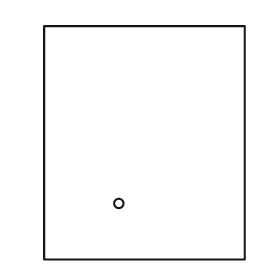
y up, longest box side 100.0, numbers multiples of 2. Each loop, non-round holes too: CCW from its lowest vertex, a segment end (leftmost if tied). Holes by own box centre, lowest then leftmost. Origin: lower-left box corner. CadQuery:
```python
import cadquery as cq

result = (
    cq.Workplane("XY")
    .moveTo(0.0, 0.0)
    .lineTo(86.0, 0.0)
    .lineTo(86.0, 100.0)
    .lineTo(0.0, 100.0)
    .close()
    .moveTo(32.0, 24.0)
    .circle(2.0)
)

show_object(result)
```